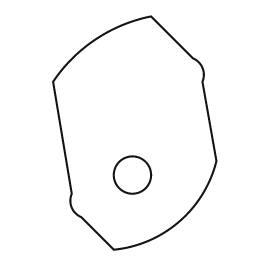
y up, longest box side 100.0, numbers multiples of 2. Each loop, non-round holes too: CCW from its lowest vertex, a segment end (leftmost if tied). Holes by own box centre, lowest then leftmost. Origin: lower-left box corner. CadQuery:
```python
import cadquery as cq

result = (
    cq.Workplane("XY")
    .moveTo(26.0, 0.0)
    .threePointArc((54.0, 12.0), (70.0, 38.0))
    .lineTo(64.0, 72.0)
    .threePointArc((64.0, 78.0), (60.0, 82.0))
    .lineTo(42.0, 100.0)
    .threePointArc((18.0, 90.0), (0.0, 72.0))
    .lineTo(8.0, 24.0)
    .threePointArc((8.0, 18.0), (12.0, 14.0))
    .close()
    .moveTo(34.0, 32.0)
    .circle(8.0)
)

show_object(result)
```